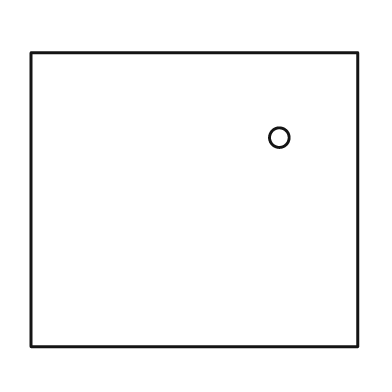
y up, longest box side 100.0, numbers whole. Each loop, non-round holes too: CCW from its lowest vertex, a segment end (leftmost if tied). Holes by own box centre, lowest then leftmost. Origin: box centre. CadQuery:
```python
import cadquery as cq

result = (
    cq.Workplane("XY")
    .moveTo(-50.0, -45.0)
    .lineTo(50.0, -45.0)
    .lineTo(50.0, 45.0)
    .lineTo(-50.0, 45.0)
    .close()
    .moveTo(26.0, 19.0)
    .circle(3.0)
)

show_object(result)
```